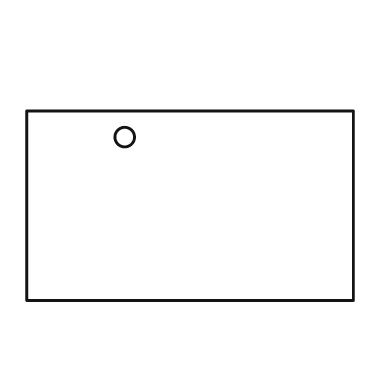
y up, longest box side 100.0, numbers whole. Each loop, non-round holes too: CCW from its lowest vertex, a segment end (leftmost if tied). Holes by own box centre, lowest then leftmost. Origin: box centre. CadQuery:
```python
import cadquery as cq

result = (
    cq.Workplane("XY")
    .moveTo(-50.0, -29.0)
    .lineTo(50.0, -29.0)
    .lineTo(50.0, 29.0)
    .lineTo(-50.0, 29.0)
    .close()
    .moveTo(-20.0, 21.0)
    .circle(3.0)
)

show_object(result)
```